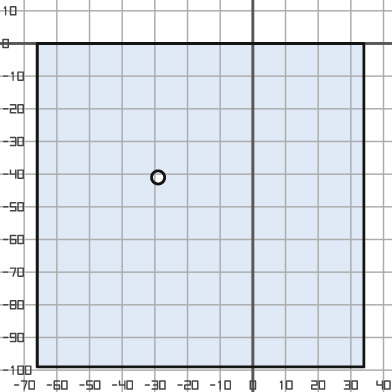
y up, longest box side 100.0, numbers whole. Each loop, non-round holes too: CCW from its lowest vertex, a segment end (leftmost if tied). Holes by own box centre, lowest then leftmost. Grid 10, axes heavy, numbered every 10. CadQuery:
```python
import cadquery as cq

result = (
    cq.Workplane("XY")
    .moveTo(-66.0, -99.0)
    .lineTo(34.0, -99.0)
    .lineTo(34.0, 0.0)
    .lineTo(-66.0, 0.0)
    .close()
    .moveTo(-29.0, -41.0)
    .circle(2.0)
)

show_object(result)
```